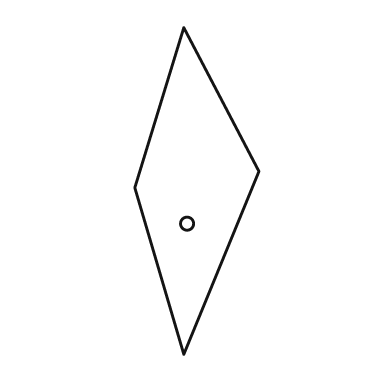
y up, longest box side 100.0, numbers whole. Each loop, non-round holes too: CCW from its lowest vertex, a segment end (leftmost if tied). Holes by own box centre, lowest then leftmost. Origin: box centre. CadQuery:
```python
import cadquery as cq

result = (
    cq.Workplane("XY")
    .moveTo(-4.0, -50.0)
    .lineTo(19.0, 6.0)
    .lineTo(-4.0, 50.0)
    .lineTo(-19.0, 1.0)
    .close()
    .moveTo(-3.0, -10.0)
    .circle(2.0)
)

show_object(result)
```